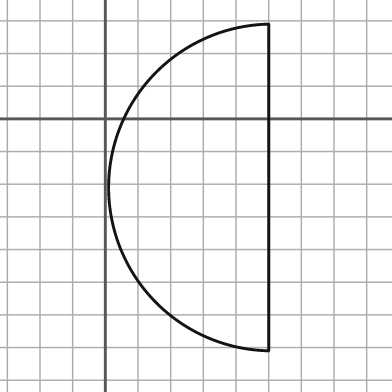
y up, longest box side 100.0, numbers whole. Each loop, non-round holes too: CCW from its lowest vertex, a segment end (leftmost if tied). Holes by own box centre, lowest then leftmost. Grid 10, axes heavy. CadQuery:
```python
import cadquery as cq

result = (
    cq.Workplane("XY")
    .moveTo(50.0, -71.0)
    .lineTo(50.0, 29.0)
    .threePointArc((1.0, -21.0), (50.0, -71.0))
    .close()
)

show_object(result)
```